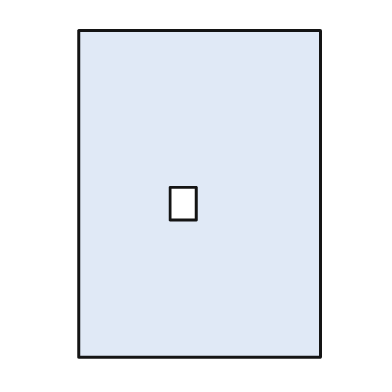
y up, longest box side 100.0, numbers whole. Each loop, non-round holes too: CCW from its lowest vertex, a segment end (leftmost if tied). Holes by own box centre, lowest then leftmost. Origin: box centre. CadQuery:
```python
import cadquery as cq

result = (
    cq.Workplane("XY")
    .moveTo(-37.0, -50.0)
    .lineTo(37.0, -50.0)
    .lineTo(37.0, 50.0)
    .lineTo(-37.0, 50.0)
    .close()
    .moveTo(-9.0, -8.0)
    .lineTo(-1.0, -8.0)
    .lineTo(-1.0, 2.0)
    .lineTo(-9.0, 2.0)
    .close()
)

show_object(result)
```